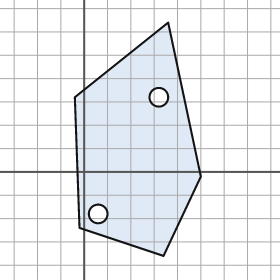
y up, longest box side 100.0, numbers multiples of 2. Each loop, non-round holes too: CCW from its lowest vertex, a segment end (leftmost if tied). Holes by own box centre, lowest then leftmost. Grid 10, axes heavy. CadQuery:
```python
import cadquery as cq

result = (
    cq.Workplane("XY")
    .moveTo(34.0, -36.0)
    .lineTo(50.0, -2.0)
    .lineTo(36.0, 64.0)
    .lineTo(-4.0, 32.0)
    .lineTo(-2.0, -24.0)
    .close()
    .moveTo(6.0, -18.0)
    .circle(4.0)
    .moveTo(32.0, 32.0)
    .circle(4.0)
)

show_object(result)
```